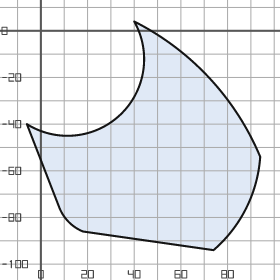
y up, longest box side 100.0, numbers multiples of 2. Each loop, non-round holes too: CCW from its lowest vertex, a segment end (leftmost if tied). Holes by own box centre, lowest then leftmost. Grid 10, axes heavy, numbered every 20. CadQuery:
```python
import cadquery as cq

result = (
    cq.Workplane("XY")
    .moveTo(74.0, -94.0)
    .threePointArc((88.0, -76.0), (94.0, -54.0))
    .threePointArc((72.0, -20.0), (40.0, 4.0))
    .threePointArc((34.0, -36.0), (-6.0, -40.0))
    .lineTo(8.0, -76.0)
    .threePointArc((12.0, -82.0), (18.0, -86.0))
    .close()
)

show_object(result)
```